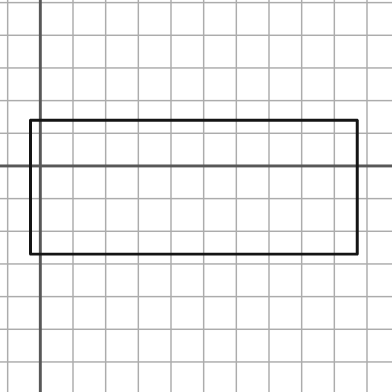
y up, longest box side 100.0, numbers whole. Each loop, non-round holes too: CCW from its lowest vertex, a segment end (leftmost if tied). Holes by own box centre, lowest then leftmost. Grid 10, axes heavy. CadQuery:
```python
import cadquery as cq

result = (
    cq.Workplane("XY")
    .moveTo(-3.0, -27.0)
    .lineTo(97.0, -27.0)
    .lineTo(97.0, 14.0)
    .lineTo(-3.0, 14.0)
    .close()
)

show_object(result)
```